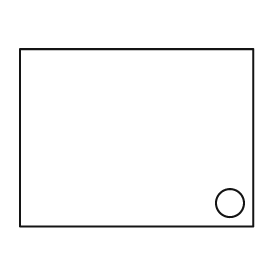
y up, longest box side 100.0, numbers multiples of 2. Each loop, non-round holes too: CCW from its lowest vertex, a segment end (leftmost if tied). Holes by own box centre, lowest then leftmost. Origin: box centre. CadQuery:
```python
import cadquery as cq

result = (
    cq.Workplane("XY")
    .moveTo(-50.0, -38.0)
    .lineTo(50.0, -38.0)
    .lineTo(50.0, 38.0)
    .lineTo(-50.0, 38.0)
    .close()
    .moveTo(40.0, -28.0)
    .circle(6.0)
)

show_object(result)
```